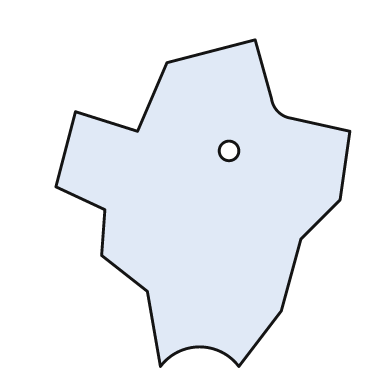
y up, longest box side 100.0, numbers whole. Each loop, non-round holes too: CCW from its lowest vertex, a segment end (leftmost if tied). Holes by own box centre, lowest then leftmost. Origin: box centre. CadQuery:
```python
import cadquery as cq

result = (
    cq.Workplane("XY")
    .moveTo(-13.0, -50.0)
    .threePointArc((-1.0, -44.0), (11.0, -50.0))
    .lineTo(24.0, -33.0)
    .lineTo(30.0, -11.0)
    .lineTo(42.0, 1.0)
    .lineTo(45.0, 22.0)
    .lineTo(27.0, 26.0)
    .threePointArc((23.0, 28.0), (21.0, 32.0))
    .lineTo(16.0, 50.0)
    .lineTo(-11.0, 43.0)
    .lineTo(-20.0, 22.0)
    .lineTo(-39.0, 28.0)
    .lineTo(-45.0, 5.0)
    .lineTo(-30.0, -2.0)
    .lineTo(-31.0, -16.0)
    .lineTo(-17.0, -27.0)
    .close()
    .moveTo(8.0, 16.0)
    .circle(3.0)
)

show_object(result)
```